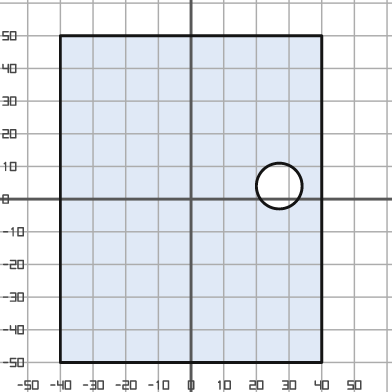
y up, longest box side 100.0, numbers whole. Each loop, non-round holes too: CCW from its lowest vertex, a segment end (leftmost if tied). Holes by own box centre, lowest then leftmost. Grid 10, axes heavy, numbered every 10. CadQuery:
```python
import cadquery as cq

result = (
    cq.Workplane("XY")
    .moveTo(-40.0, -50.0)
    .lineTo(40.0, -50.0)
    .lineTo(40.0, 50.0)
    .lineTo(-40.0, 50.0)
    .close()
    .moveTo(27.0, 4.0)
    .circle(7.0)
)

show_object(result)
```